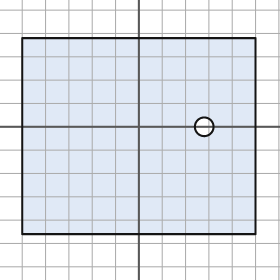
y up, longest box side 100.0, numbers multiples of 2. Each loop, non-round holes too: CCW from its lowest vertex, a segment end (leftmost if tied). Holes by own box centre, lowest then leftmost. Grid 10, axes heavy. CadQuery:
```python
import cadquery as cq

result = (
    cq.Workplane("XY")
    .moveTo(-50.0, -46.0)
    .lineTo(50.0, -46.0)
    .lineTo(50.0, 38.0)
    .lineTo(-50.0, 38.0)
    .close()
    .moveTo(28.0, 0.0)
    .circle(4.0)
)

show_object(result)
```